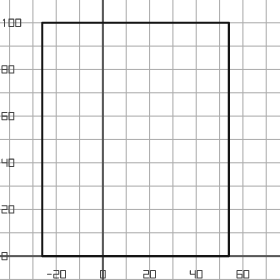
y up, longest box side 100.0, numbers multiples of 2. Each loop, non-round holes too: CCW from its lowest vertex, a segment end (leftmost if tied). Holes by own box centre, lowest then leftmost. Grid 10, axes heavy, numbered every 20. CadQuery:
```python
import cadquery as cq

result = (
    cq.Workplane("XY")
    .moveTo(-26.0, 0.0)
    .lineTo(54.0, 0.0)
    .lineTo(54.0, 100.0)
    .lineTo(-26.0, 100.0)
    .close()
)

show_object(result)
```